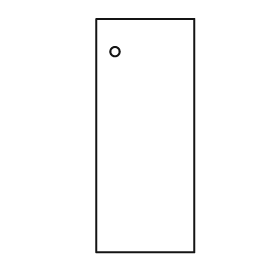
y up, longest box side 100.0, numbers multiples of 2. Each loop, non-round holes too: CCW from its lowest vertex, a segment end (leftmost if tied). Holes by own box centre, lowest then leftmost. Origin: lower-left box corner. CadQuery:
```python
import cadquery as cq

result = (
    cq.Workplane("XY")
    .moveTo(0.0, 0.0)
    .lineTo(42.0, 0.0)
    .lineTo(42.0, 100.0)
    .lineTo(0.0, 100.0)
    .close()
    .moveTo(8.0, 86.0)
    .circle(2.0)
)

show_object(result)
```